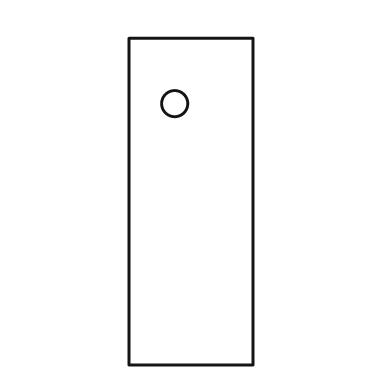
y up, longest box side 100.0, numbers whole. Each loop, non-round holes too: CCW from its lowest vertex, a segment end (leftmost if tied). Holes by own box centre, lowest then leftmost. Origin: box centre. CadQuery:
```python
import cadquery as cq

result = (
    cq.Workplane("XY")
    .moveTo(-19.0, -50.0)
    .lineTo(19.0, -50.0)
    .lineTo(19.0, 50.0)
    .lineTo(-19.0, 50.0)
    .close()
    .moveTo(-5.0, 30.0)
    .circle(4.0)
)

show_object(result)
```